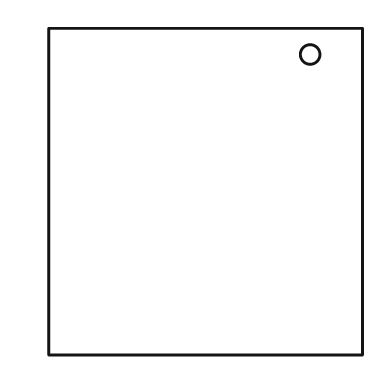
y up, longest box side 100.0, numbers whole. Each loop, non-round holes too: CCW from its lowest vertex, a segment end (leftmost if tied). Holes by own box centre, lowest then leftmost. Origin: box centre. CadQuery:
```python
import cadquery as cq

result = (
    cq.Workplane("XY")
    .moveTo(-48.0, -50.0)
    .lineTo(48.0, -50.0)
    .lineTo(48.0, 50.0)
    .lineTo(-48.0, 50.0)
    .close()
    .moveTo(32.0, 42.0)
    .circle(3.0)
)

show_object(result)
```